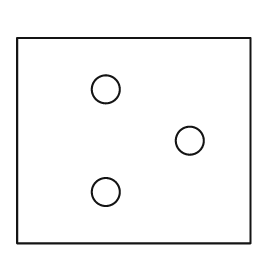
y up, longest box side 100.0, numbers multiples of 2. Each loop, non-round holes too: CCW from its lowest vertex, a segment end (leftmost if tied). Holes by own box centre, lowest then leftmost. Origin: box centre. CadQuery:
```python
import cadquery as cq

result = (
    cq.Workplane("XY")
    .moveTo(-50.0, -44.0)
    .lineTo(50.0, -44.0)
    .lineTo(50.0, 44.0)
    .lineTo(-50.0, 44.0)
    .close()
    .moveTo(-12.0, -22.0)
    .circle(6.0)
    .moveTo(24.0, 0.0)
    .circle(6.0)
    .moveTo(-12.0, 22.0)
    .circle(6.0)
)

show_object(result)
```